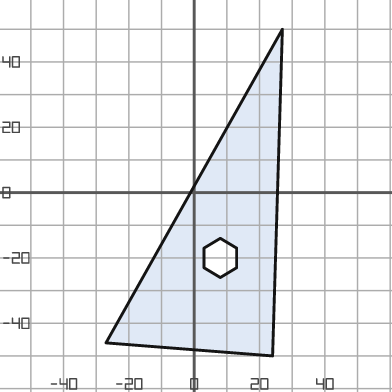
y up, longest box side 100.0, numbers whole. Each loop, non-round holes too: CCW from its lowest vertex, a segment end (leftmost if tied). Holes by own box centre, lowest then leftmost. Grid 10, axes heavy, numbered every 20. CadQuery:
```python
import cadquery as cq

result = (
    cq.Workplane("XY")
    .moveTo(24.0, -50.0)
    .lineTo(27.0, 50.0)
    .lineTo(-27.0, -46.0)
    .close()
    .moveTo(8.0, -26.0)
    .lineTo(13.0, -23.0)
    .lineTo(13.0, -17.0)
    .lineTo(8.0, -14.0)
    .lineTo(3.0, -17.0)
    .lineTo(3.0, -23.0)
    .close()
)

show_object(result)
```